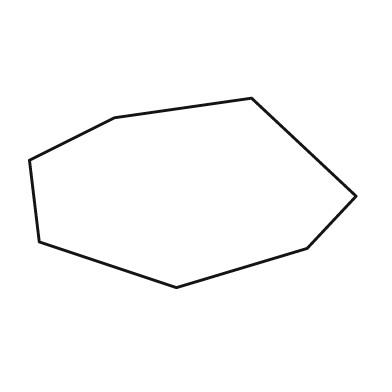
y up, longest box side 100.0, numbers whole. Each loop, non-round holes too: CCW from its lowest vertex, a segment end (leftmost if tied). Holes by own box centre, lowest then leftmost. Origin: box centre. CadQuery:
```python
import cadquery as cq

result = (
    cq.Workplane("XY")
    .moveTo(-5.0, -29.0)
    .lineTo(35.0, -17.0)
    .lineTo(50.0, -1.0)
    .lineTo(18.0, 29.0)
    .lineTo(-24.0, 23.0)
    .lineTo(-50.0, 10.0)
    .lineTo(-47.0, -15.0)
    .close()
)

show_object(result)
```